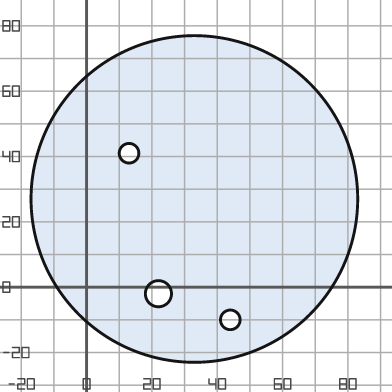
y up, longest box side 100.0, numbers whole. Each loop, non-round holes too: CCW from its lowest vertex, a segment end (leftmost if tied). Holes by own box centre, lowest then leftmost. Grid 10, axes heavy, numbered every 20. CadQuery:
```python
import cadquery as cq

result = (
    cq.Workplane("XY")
    .moveTo(33.0, 27.0)
    .circle(50.0)
    .moveTo(44.0, -10.0)
    .circle(3.0)
    .moveTo(22.0, -2.0)
    .circle(4.0)
    .moveTo(13.0, 41.0)
    .circle(3.0)
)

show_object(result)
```